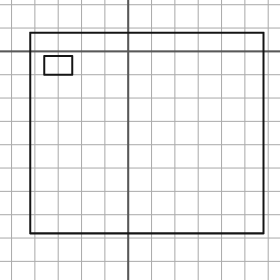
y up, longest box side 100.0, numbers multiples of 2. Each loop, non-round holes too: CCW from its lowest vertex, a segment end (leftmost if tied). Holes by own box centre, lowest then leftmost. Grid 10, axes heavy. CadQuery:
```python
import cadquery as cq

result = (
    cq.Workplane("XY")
    .moveTo(-42.0, -78.0)
    .lineTo(58.0, -78.0)
    .lineTo(58.0, 8.0)
    .lineTo(-42.0, 8.0)
    .close()
    .moveTo(-36.0, -10.0)
    .lineTo(-24.0, -10.0)
    .lineTo(-24.0, -2.0)
    .lineTo(-36.0, -2.0)
    .close()
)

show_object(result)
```